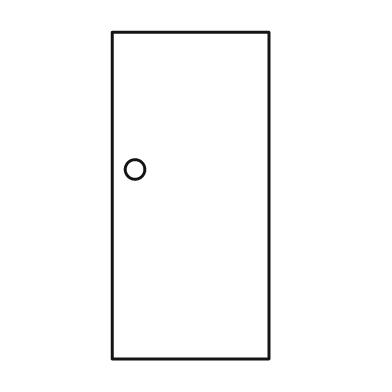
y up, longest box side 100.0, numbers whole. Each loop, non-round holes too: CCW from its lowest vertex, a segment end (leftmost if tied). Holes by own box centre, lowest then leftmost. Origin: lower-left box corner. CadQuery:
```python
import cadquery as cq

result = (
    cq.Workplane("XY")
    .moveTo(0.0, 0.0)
    .lineTo(48.0, 0.0)
    .lineTo(48.0, 100.0)
    .lineTo(0.0, 100.0)
    .close()
    .moveTo(7.0, 58.0)
    .circle(3.0)
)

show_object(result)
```